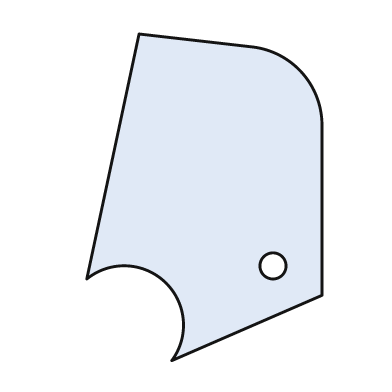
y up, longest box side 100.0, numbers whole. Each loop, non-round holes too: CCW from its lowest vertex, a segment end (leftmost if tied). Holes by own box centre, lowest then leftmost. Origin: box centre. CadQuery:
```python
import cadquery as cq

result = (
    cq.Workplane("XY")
    .moveTo(-10.0, -50.0)
    .lineTo(36.0, -30.0)
    .lineTo(36.0, 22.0)
    .threePointArc((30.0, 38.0), (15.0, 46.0))
    .lineTo(-20.0, 50.0)
    .lineTo(-36.0, -25.0)
    .threePointArc((-12.0, -26.0), (-10.0, -50.0))
    .close()
    .moveTo(21.0, -21.0)
    .circle(4.0)
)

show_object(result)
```